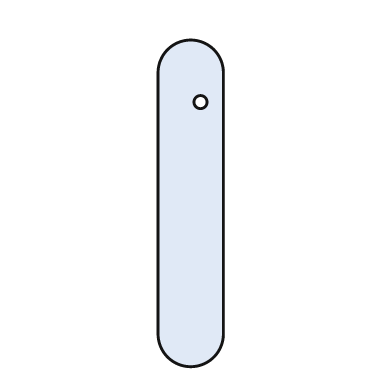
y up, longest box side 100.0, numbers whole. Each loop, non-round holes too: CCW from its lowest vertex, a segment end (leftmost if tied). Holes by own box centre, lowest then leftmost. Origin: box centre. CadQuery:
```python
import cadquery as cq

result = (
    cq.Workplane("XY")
    .moveTo(-10.0, -40.0)
    .threePointArc((0.0, -50.0), (10.0, -40.0))
    .lineTo(10.0, 40.0)
    .threePointArc((0.0, 50.0), (-10.0, 40.0))
    .close()
    .moveTo(3.0, 31.0)
    .circle(2.0)
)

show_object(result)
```